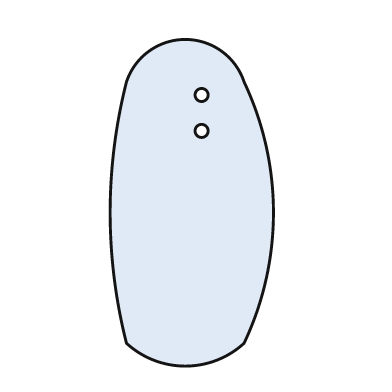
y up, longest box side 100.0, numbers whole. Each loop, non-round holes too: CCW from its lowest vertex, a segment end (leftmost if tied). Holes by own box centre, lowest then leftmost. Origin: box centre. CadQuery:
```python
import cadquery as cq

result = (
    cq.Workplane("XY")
    .moveTo(-20.0, -43.0)
    .threePointArc((-2.0, -50.0), (16.0, -43.0))
    .threePointArc((25.0, -3.0), (16.0, 37.0))
    .threePointArc((-2.0, 50.0), (-20.0, 37.0))
    .threePointArc((-25.0, -3.0), (-20.0, -43.0))
    .close()
    .moveTo(3.0, 22.0)
    .circle(2.0)
    .moveTo(3.0, 33.0)
    .circle(2.0)
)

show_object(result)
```